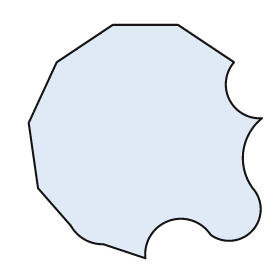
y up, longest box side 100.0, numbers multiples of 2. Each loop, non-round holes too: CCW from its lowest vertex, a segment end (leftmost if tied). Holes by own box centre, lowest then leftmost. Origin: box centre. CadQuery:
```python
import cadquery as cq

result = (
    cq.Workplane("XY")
    .moveTo(0.0, -50.0)
    .threePointArc((10.0, -34.0), (28.0, -40.0))
    .threePointArc((46.0, -38.0), (46.0, -20.0))
    .threePointArc((42.0, -4.0), (50.0, 10.0))
    .threePointArc((36.0, 18.0), (38.0, 34.0))
    .lineTo(14.0, 50.0)
    .lineTo(-14.0, 50.0)
    .lineTo(-38.0, 34.0)
    .lineTo(-50.0, 8.0)
    .lineTo(-46.0, -20.0)
    .lineTo(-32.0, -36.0)
    .threePointArc((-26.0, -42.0), (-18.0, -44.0))
    .close()
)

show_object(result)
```